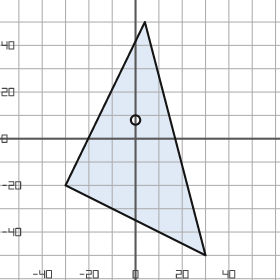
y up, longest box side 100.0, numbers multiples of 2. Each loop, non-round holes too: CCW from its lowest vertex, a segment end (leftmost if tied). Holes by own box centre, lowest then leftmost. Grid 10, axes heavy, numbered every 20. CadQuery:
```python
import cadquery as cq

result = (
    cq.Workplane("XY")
    .moveTo(30.0, -50.0)
    .lineTo(4.0, 50.0)
    .lineTo(-30.0, -20.0)
    .close()
    .moveTo(0.0, 8.0)
    .circle(2.0)
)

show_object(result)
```